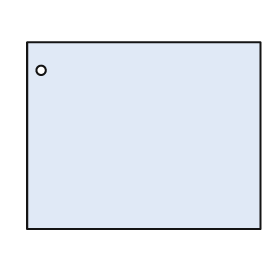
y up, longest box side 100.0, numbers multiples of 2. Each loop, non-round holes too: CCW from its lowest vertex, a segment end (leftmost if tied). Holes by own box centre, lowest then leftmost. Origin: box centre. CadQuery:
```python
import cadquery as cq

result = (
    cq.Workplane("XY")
    .moveTo(-50.0, -40.0)
    .lineTo(50.0, -40.0)
    .lineTo(50.0, 40.0)
    .lineTo(-50.0, 40.0)
    .close()
    .moveTo(-44.0, 28.0)
    .circle(2.0)
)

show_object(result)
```